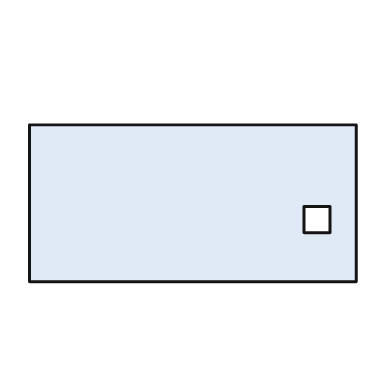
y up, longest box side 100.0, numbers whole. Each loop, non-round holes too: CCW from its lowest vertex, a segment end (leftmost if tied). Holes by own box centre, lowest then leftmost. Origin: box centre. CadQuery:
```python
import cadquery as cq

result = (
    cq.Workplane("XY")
    .moveTo(-50.0, -24.0)
    .lineTo(50.0, -24.0)
    .lineTo(50.0, 24.0)
    .lineTo(-50.0, 24.0)
    .close()
    .moveTo(34.0, -9.0)
    .lineTo(42.0, -9.0)
    .lineTo(42.0, -1.0)
    .lineTo(34.0, -1.0)
    .close()
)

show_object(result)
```